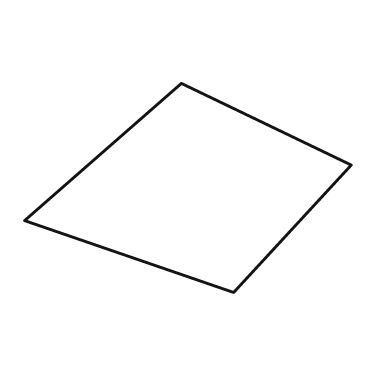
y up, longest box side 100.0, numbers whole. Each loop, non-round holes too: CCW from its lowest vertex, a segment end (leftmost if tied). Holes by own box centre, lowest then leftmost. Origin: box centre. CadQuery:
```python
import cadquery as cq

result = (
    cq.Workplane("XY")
    .moveTo(14.0, -32.0)
    .lineTo(50.0, 7.0)
    .lineTo(-2.0, 32.0)
    .lineTo(-50.0, -10.0)
    .close()
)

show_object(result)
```